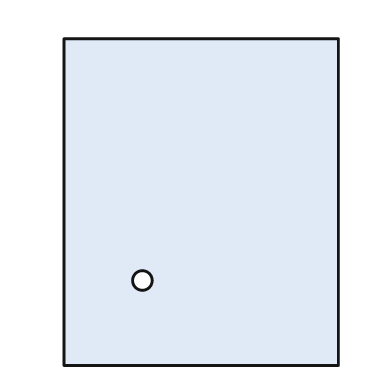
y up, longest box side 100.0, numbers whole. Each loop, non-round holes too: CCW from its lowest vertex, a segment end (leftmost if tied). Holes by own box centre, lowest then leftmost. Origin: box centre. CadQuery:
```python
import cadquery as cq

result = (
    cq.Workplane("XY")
    .moveTo(-42.0, -50.0)
    .lineTo(42.0, -50.0)
    .lineTo(42.0, 50.0)
    .lineTo(-42.0, 50.0)
    .close()
    .moveTo(-18.0, -24.0)
    .circle(3.0)
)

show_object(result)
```